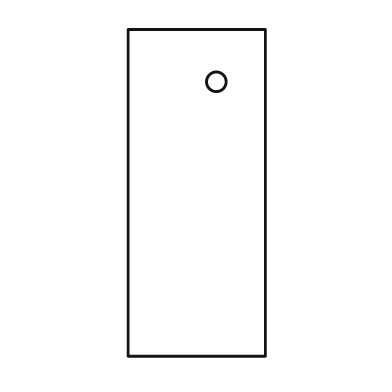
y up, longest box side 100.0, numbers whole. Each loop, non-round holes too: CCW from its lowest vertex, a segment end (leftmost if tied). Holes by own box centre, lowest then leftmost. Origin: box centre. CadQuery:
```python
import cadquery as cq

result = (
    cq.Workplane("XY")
    .moveTo(-21.0, -50.0)
    .lineTo(21.0, -50.0)
    .lineTo(21.0, 50.0)
    .lineTo(-21.0, 50.0)
    .close()
    .moveTo(6.0, 34.0)
    .circle(3.0)
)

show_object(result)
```